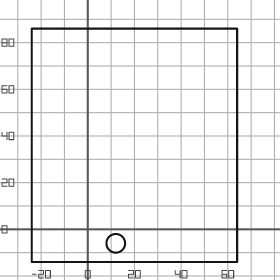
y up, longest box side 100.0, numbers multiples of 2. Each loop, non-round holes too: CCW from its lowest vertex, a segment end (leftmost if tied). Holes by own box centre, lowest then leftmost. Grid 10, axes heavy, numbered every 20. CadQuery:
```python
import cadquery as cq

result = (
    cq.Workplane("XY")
    .moveTo(-24.0, -14.0)
    .lineTo(64.0, -14.0)
    .lineTo(64.0, 86.0)
    .lineTo(-24.0, 86.0)
    .close()
    .moveTo(12.0, -6.0)
    .circle(4.0)
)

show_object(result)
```